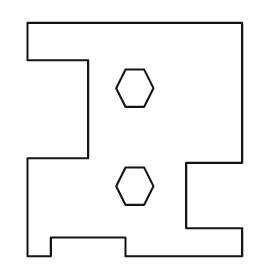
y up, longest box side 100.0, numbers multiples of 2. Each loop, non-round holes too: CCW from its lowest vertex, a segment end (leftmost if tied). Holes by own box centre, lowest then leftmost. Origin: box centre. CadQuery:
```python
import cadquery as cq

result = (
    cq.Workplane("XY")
    .moveTo(-46.0, -50.0)
    .lineTo(-36.0, -50.0)
    .lineTo(-36.0, -42.0)
    .lineTo(-4.0, -42.0)
    .lineTo(-4.0, -50.0)
    .lineTo(46.0, -50.0)
    .lineTo(46.0, -38.0)
    .lineTo(22.0, -38.0)
    .lineTo(22.0, -10.0)
    .lineTo(46.0, -10.0)
    .lineTo(46.0, 50.0)
    .lineTo(-46.0, 50.0)
    .lineTo(-46.0, 34.0)
    .lineTo(-20.0, 34.0)
    .lineTo(-20.0, -8.0)
    .lineTo(-46.0, -8.0)
    .close()
    .moveTo(-4.0, -28.0)
    .lineTo(4.0, -28.0)
    .lineTo(8.0, -20.0)
    .lineTo(4.0, -12.0)
    .lineTo(-4.0, -12.0)
    .lineTo(-8.0, -20.0)
    .close()
    .moveTo(-4.0, 14.0)
    .lineTo(4.0, 14.0)
    .lineTo(8.0, 22.0)
    .lineTo(4.0, 30.0)
    .lineTo(-4.0, 30.0)
    .lineTo(-8.0, 22.0)
    .close()
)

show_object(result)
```